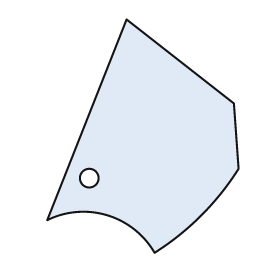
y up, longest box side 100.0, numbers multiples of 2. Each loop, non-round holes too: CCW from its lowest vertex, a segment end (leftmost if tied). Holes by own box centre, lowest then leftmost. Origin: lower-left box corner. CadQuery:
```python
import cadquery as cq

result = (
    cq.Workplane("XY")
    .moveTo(46.0, 0.0)
    .threePointArc((66.0, 16.0), (82.0, 36.0))
    .lineTo(80.0, 64.0)
    .lineTo(34.0, 100.0)
    .lineTo(0.0, 14.0)
    .threePointArc((26.0, 16.0), (46.0, 0.0))
    .close()
    .moveTo(18.0, 32.0)
    .circle(4.0)
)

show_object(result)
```